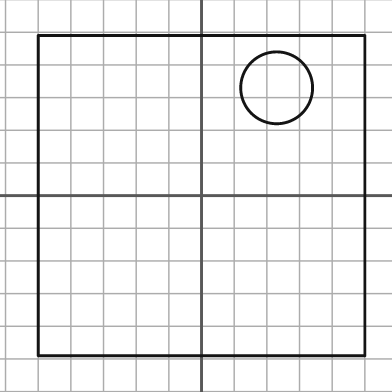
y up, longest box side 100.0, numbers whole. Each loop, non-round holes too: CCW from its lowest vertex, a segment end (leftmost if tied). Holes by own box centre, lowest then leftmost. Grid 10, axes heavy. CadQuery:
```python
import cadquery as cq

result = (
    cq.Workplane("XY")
    .moveTo(-50.0, -49.0)
    .lineTo(50.0, -49.0)
    .lineTo(50.0, 49.0)
    .lineTo(-50.0, 49.0)
    .close()
    .moveTo(23.0, 33.0)
    .circle(11.0)
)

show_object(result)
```